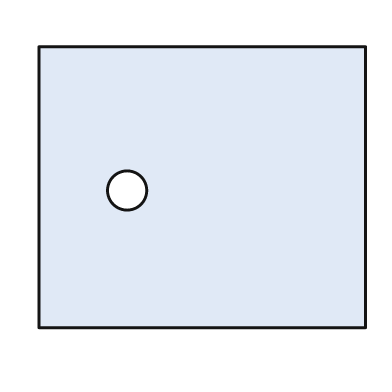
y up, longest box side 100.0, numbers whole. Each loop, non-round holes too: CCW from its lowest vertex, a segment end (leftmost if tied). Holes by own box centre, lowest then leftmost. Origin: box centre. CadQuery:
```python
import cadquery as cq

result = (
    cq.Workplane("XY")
    .moveTo(-50.0, -43.0)
    .lineTo(50.0, -43.0)
    .lineTo(50.0, 43.0)
    .lineTo(-50.0, 43.0)
    .close()
    .moveTo(-23.0, -1.0)
    .circle(6.0)
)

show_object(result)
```